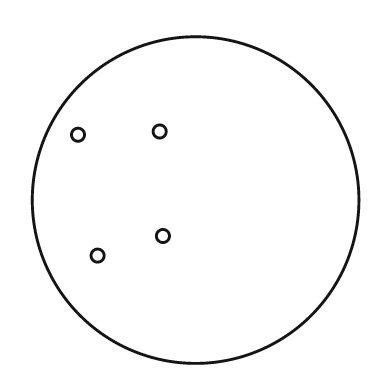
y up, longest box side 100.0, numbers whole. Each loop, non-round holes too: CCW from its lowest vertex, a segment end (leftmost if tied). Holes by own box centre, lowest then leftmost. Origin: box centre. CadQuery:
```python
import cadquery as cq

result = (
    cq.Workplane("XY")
    .moveTo(0.0, 0.0)
    .circle(50.0)
    .moveTo(-30.0, -17.0)
    .circle(2.0)
    .moveTo(-10.0, -11.0)
    .circle(2.0)
    .moveTo(-36.0, 20.0)
    .circle(2.0)
    .moveTo(-11.0, 21.0)
    .circle(2.0)
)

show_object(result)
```